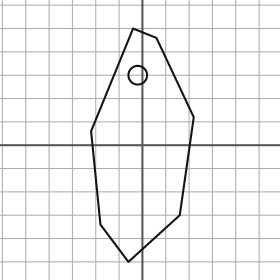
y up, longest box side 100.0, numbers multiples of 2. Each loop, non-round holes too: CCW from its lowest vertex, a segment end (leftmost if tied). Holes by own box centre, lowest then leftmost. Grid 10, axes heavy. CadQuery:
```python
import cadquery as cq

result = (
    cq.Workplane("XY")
    .moveTo(-6.0, -50.0)
    .lineTo(16.0, -30.0)
    .lineTo(22.0, 12.0)
    .lineTo(6.0, 46.0)
    .lineTo(-4.0, 50.0)
    .lineTo(-22.0, 6.0)
    .lineTo(-18.0, -34.0)
    .close()
    .moveTo(-2.0, 30.0)
    .circle(4.0)
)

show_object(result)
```